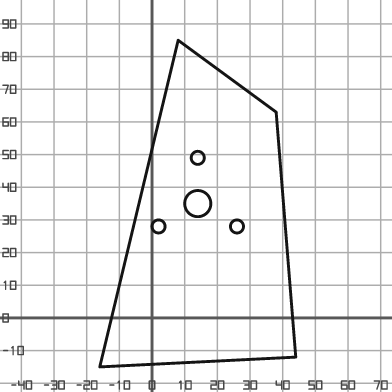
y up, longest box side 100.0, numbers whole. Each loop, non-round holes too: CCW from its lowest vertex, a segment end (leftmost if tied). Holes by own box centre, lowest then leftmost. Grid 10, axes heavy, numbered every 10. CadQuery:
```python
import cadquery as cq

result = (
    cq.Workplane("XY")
    .moveTo(-16.0, -15.0)
    .lineTo(44.0, -12.0)
    .lineTo(38.0, 63.0)
    .lineTo(8.0, 85.0)
    .close()
    .moveTo(2.0, 28.0)
    .circle(2.0)
    .moveTo(26.0, 28.0)
    .circle(2.0)
    .moveTo(14.0, 35.0)
    .circle(4.0)
    .moveTo(14.0, 49.0)
    .circle(2.0)
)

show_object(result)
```